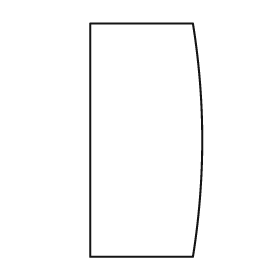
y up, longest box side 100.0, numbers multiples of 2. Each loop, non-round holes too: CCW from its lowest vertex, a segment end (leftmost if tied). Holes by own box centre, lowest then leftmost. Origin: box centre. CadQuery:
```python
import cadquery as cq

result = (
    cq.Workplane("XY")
    .moveTo(-24.0, -50.0)
    .lineTo(20.0, -50.0)
    .threePointArc((24.0, 0.0), (20.0, 50.0))
    .lineTo(-24.0, 50.0)
    .close()
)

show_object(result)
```